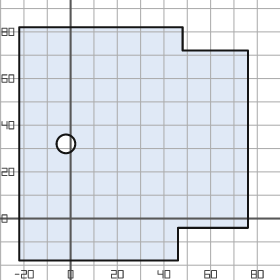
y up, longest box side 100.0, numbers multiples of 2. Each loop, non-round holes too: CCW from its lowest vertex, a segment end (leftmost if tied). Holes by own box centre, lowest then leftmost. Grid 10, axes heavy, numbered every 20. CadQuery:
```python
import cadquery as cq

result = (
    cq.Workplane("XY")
    .moveTo(-22.0, -18.0)
    .lineTo(46.0, -18.0)
    .lineTo(46.0, -4.0)
    .lineTo(76.0, -4.0)
    .lineTo(76.0, 72.0)
    .lineTo(48.0, 72.0)
    .lineTo(48.0, 82.0)
    .lineTo(-22.0, 82.0)
    .close()
    .moveTo(-2.0, 32.0)
    .circle(4.0)
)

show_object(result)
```